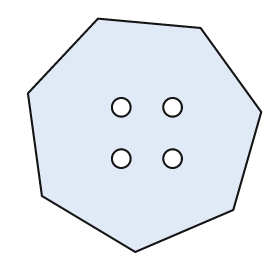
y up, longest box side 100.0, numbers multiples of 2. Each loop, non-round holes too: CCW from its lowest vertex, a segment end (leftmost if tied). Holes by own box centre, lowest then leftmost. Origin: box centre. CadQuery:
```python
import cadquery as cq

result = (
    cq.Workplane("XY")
    .moveTo(-4.0, -50.0)
    .lineTo(38.0, -32.0)
    .lineTo(50.0, 10.0)
    .lineTo(24.0, 46.0)
    .lineTo(-20.0, 50.0)
    .lineTo(-50.0, 18.0)
    .lineTo(-44.0, -26.0)
    .close()
    .moveTo(-10.0, -10.0)
    .circle(4.0)
    .moveTo(12.0, -10.0)
    .circle(4.0)
    .moveTo(-10.0, 12.0)
    .circle(4.0)
    .moveTo(12.0, 12.0)
    .circle(4.0)
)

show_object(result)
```